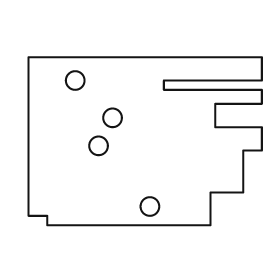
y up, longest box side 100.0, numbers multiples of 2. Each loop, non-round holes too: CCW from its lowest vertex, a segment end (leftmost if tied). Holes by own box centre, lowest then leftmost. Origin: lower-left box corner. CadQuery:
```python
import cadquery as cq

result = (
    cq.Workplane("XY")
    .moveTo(8.0, 0.0)
    .lineTo(78.0, 0.0)
    .lineTo(78.0, 14.0)
    .lineTo(92.0, 14.0)
    .lineTo(92.0, 32.0)
    .lineTo(100.0, 32.0)
    .lineTo(100.0, 42.0)
    .lineTo(80.0, 42.0)
    .lineTo(80.0, 52.0)
    .lineTo(100.0, 52.0)
    .lineTo(100.0, 58.0)
    .lineTo(58.0, 58.0)
    .lineTo(58.0, 62.0)
    .lineTo(100.0, 62.0)
    .lineTo(100.0, 72.0)
    .lineTo(0.0, 72.0)
    .lineTo(0.0, 4.0)
    .lineTo(8.0, 4.0)
    .close()
    .moveTo(52.0, 8.0)
    .circle(4.0)
    .moveTo(30.0, 34.0)
    .circle(4.0)
    .moveTo(36.0, 46.0)
    .circle(4.0)
    .moveTo(20.0, 62.0)
    .circle(4.0)
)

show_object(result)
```